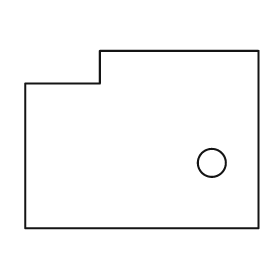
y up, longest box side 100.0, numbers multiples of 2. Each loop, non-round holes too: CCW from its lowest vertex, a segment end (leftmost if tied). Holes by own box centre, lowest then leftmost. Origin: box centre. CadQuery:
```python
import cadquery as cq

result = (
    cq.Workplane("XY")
    .moveTo(-50.0, -38.0)
    .lineTo(50.0, -38.0)
    .lineTo(50.0, 38.0)
    .lineTo(-18.0, 38.0)
    .lineTo(-18.0, 24.0)
    .lineTo(-50.0, 24.0)
    .close()
    .moveTo(30.0, -10.0)
    .circle(6.0)
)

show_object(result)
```